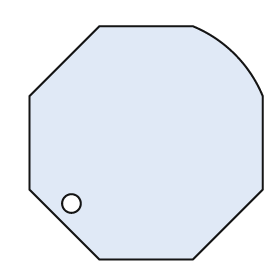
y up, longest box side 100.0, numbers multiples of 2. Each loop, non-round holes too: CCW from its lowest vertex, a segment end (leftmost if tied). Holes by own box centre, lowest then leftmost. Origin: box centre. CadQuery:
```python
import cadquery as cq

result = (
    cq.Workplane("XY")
    .moveTo(-20.0, -50.0)
    .lineTo(20.0, -50.0)
    .lineTo(50.0, -20.0)
    .lineTo(50.0, 20.0)
    .threePointArc((38.0, 38.0), (20.0, 50.0))
    .lineTo(-20.0, 50.0)
    .lineTo(-50.0, 20.0)
    .lineTo(-50.0, -20.0)
    .close()
    .moveTo(-32.0, -26.0)
    .circle(4.0)
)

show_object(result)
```